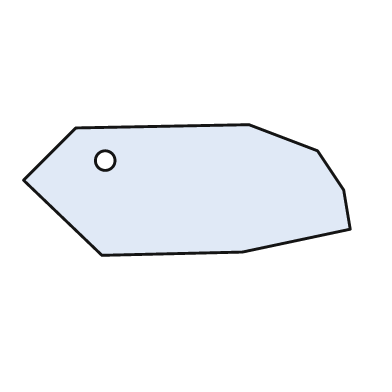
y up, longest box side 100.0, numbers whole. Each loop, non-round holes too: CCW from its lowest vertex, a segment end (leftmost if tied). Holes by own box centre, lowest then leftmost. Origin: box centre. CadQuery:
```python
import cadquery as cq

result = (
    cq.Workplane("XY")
    .moveTo(-26.0, -20.0)
    .lineTo(17.0, -19.0)
    .lineTo(50.0, -12.0)
    .lineTo(48.0, 0.0)
    .lineTo(40.0, 12.0)
    .lineTo(19.0, 20.0)
    .lineTo(-34.0, 19.0)
    .lineTo(-50.0, 3.0)
    .close()
    .moveTo(-25.0, 9.0)
    .circle(3.0)
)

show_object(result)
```